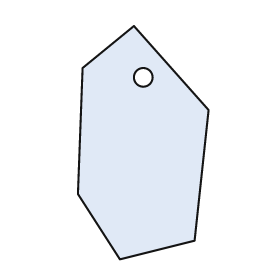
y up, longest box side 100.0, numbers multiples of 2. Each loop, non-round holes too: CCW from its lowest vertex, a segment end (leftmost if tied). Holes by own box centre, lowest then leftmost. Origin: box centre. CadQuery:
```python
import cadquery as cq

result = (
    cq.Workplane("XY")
    .moveTo(-10.0, -50.0)
    .lineTo(22.0, -42.0)
    .lineTo(28.0, 14.0)
    .lineTo(-4.0, 50.0)
    .lineTo(-26.0, 32.0)
    .lineTo(-28.0, -22.0)
    .close()
    .moveTo(0.0, 28.0)
    .circle(4.0)
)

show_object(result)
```